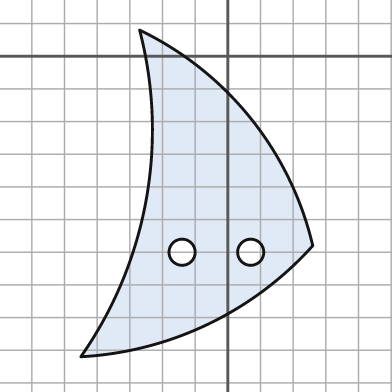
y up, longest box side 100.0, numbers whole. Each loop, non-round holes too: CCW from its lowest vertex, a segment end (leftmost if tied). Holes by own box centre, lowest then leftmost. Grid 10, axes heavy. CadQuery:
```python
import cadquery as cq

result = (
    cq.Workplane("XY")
    .moveTo(-45.0, -92.0)
    .threePointArc((-6.0, -82.0), (26.0, -58.0))
    .threePointArc((7.0, -19.0), (-27.0, 8.0))
    .threePointArc((-25.0, -44.0), (-45.0, -92.0))
    .close()
    .moveTo(-14.0, -60.0)
    .circle(4.0)
    .moveTo(7.0, -60.0)
    .circle(4.0)
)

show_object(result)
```